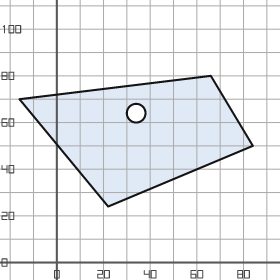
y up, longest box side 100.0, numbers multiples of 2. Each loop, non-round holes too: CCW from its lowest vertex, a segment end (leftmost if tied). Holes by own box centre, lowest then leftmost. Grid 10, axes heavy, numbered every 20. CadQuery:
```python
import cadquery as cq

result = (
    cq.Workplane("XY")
    .moveTo(22.0, 24.0)
    .lineTo(84.0, 50.0)
    .lineTo(66.0, 80.0)
    .lineTo(-16.0, 70.0)
    .close()
    .moveTo(34.0, 64.0)
    .circle(4.0)
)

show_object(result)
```